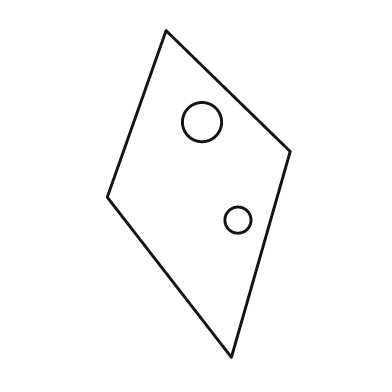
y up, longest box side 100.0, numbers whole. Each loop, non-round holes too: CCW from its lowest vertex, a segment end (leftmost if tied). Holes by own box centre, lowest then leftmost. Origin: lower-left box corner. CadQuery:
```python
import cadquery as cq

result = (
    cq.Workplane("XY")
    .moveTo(38.0, 0.0)
    .lineTo(56.0, 63.0)
    .lineTo(18.0, 100.0)
    .lineTo(0.0, 49.0)
    .close()
    .moveTo(40.0, 42.0)
    .circle(4.0)
    .moveTo(29.0, 72.0)
    .circle(6.0)
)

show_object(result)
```